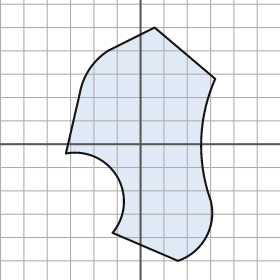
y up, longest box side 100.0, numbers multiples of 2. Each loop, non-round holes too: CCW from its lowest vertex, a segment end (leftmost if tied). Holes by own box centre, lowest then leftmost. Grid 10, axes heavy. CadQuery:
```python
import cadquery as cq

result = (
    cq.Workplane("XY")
    .moveTo(16.0, -50.0)
    .threePointArc((28.0, -40.0), (30.0, -24.0))
    .threePointArc((26.0, 2.0), (32.0, 28.0))
    .lineTo(6.0, 50.0)
    .lineTo(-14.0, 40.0)
    .threePointArc((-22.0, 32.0), (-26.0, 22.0))
    .lineTo(-32.0, -4.0)
    .threePointArc((-10.0, -14.0), (-12.0, -38.0))
    .close()
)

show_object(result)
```